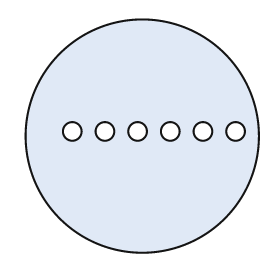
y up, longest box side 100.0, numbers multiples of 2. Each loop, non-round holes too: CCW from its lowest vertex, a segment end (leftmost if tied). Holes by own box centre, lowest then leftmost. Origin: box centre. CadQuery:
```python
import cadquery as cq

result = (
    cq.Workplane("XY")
    .moveTo(0.0, 0.0)
    .circle(50.0)
    .moveTo(-30.0, 2.0)
    .circle(4.0)
    .moveTo(-16.0, 2.0)
    .circle(4.0)
    .moveTo(-2.0, 2.0)
    .circle(4.0)
    .moveTo(12.0, 2.0)
    .circle(4.0)
    .moveTo(26.0, 2.0)
    .circle(4.0)
    .moveTo(40.0, 2.0)
    .circle(4.0)
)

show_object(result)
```